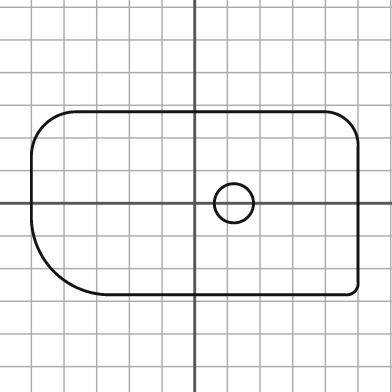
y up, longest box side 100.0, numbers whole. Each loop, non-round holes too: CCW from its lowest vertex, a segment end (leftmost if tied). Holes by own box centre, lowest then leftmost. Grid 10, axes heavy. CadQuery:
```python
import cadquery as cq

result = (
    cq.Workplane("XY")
    .moveTo(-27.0, -28.0)
    .lineTo(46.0, -28.0)
    .threePointArc((49.0, -27.0), (50.0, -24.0))
    .lineTo(50.0, 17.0)
    .threePointArc((47.0, 25.0), (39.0, 28.0))
    .lineTo(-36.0, 28.0)
    .threePointArc((-46.0, 24.0), (-50.0, 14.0))
    .lineTo(-50.0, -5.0)
    .threePointArc((-43.0, -21.0), (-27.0, -28.0))
    .close()
    .moveTo(12.0, 0.0)
    .circle(6.0)
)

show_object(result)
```